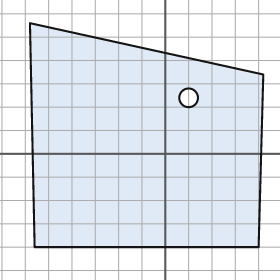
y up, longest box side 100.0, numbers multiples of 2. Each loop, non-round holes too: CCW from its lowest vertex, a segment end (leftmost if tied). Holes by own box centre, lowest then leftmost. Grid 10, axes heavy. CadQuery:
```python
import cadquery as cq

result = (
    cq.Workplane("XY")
    .moveTo(-56.0, -40.0)
    .lineTo(40.0, -40.0)
    .lineTo(42.0, 34.0)
    .lineTo(-58.0, 56.0)
    .close()
    .moveTo(10.0, 24.0)
    .circle(4.0)
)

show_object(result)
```